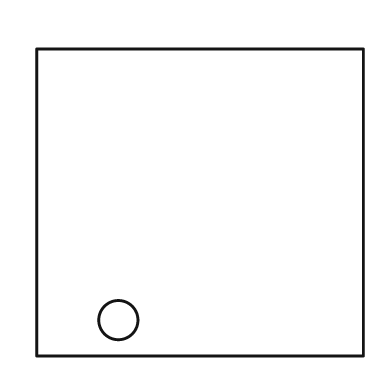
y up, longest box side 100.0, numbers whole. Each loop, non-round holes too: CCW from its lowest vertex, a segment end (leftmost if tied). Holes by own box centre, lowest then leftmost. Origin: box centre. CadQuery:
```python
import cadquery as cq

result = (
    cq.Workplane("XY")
    .moveTo(-50.0, -47.0)
    .lineTo(50.0, -47.0)
    .lineTo(50.0, 47.0)
    .lineTo(-50.0, 47.0)
    .close()
    .moveTo(-25.0, -36.0)
    .circle(6.0)
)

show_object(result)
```